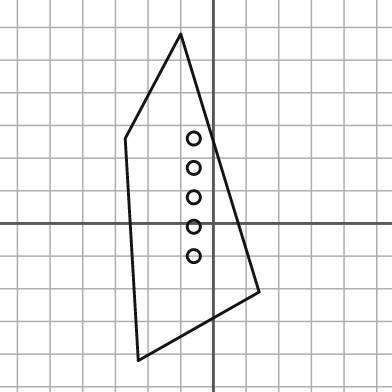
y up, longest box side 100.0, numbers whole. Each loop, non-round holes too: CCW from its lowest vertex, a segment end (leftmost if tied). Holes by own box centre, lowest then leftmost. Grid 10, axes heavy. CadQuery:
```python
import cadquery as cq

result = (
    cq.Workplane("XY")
    .moveTo(-23.0, -42.0)
    .lineTo(14.0, -21.0)
    .lineTo(-10.0, 58.0)
    .lineTo(-27.0, 26.0)
    .close()
    .moveTo(-6.0, -10.0)
    .circle(2.0)
    .moveTo(-6.0, -1.0)
    .circle(2.0)
    .moveTo(-6.0, 8.0)
    .circle(2.0)
    .moveTo(-6.0, 17.0)
    .circle(2.0)
    .moveTo(-6.0, 26.0)
    .circle(2.0)
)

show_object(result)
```